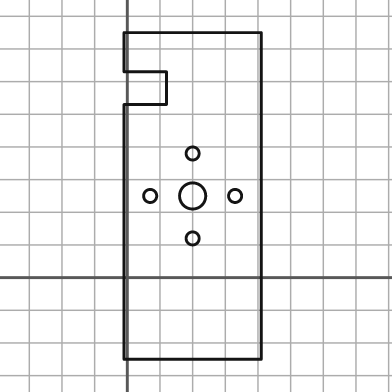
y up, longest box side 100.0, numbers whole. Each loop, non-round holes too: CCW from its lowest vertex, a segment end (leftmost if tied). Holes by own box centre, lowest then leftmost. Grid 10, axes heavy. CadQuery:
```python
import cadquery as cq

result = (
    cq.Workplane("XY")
    .moveTo(-1.0, -25.0)
    .lineTo(41.0, -25.0)
    .lineTo(41.0, 75.0)
    .lineTo(-1.0, 75.0)
    .lineTo(-1.0, 63.0)
    .lineTo(12.0, 63.0)
    .lineTo(12.0, 53.0)
    .lineTo(-1.0, 53.0)
    .close()
    .moveTo(20.0, 12.0)
    .circle(2.0)
    .moveTo(7.0, 25.0)
    .circle(2.0)
    .moveTo(20.0, 25.0)
    .circle(4.0)
    .moveTo(33.0, 25.0)
    .circle(2.0)
    .moveTo(20.0, 38.0)
    .circle(2.0)
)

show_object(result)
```